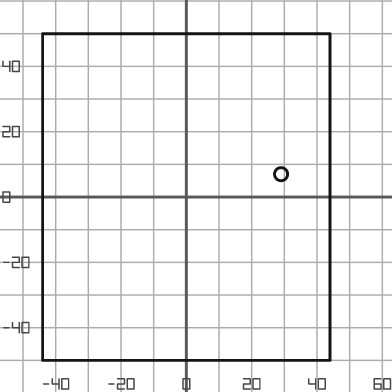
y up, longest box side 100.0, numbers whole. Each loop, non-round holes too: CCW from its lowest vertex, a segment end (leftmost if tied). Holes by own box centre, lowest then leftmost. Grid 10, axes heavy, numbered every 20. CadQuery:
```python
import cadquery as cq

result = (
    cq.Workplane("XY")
    .moveTo(-44.0, -50.0)
    .lineTo(44.0, -50.0)
    .lineTo(44.0, 50.0)
    .lineTo(-44.0, 50.0)
    .close()
    .moveTo(29.0, 7.0)
    .circle(2.0)
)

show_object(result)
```